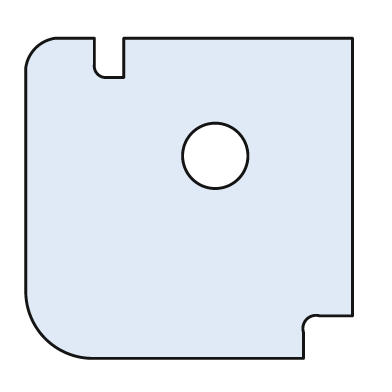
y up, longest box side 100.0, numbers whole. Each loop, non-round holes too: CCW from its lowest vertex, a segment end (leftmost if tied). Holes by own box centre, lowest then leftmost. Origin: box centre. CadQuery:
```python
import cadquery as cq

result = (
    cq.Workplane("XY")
    .moveTo(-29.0, -49.0)
    .lineTo(35.0, -49.0)
    .lineTo(35.0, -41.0)
    .threePointArc((36.0, -37.0), (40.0, -36.0))
    .lineTo(50.0, -36.0)
    .lineTo(50.0, 49.0)
    .lineTo(-20.0, 49.0)
    .lineTo(-20.0, 37.0)
    .lineTo(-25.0, 37.0)
    .threePointArc((-28.0, 38.0), (-29.0, 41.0))
    .lineTo(-29.0, 49.0)
    .lineTo(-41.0, 49.0)
    .threePointArc((-47.0, 46.0), (-50.0, 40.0))
    .lineTo(-50.0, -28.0)
    .threePointArc((-44.0, -43.0), (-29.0, -49.0))
    .close()
    .moveTo(8.0, 13.0)
    .circle(10.0)
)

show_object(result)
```